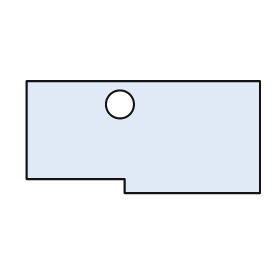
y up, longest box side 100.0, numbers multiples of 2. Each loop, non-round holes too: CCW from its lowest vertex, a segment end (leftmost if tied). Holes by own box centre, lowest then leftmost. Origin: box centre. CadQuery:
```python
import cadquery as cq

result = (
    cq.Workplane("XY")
    .moveTo(-8.0, -24.0)
    .lineTo(50.0, -24.0)
    .lineTo(50.0, 24.0)
    .lineTo(-50.0, 24.0)
    .lineTo(-50.0, -18.0)
    .lineTo(-8.0, -18.0)
    .close()
    .moveTo(-10.0, 14.0)
    .circle(6.0)
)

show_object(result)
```